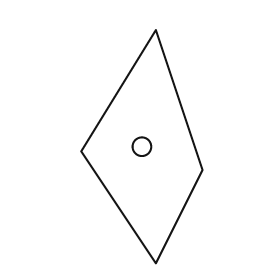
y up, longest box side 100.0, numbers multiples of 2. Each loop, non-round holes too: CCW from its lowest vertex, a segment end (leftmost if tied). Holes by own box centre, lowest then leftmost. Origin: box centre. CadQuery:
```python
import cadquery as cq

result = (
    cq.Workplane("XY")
    .moveTo(6.0, -50.0)
    .lineTo(26.0, -10.0)
    .lineTo(6.0, 50.0)
    .lineTo(-26.0, -2.0)
    .close()
    .moveTo(0.0, 0.0)
    .circle(4.0)
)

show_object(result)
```